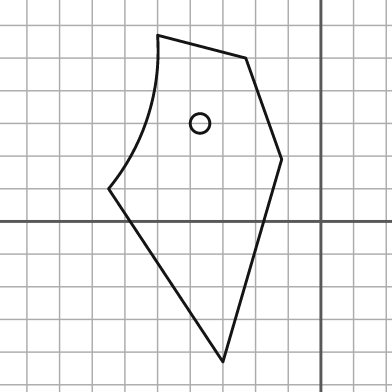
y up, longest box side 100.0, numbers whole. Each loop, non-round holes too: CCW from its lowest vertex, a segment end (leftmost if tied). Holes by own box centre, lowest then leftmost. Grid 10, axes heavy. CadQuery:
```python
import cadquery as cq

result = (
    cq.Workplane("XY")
    .moveTo(-30.0, -43.0)
    .lineTo(-12.0, 19.0)
    .lineTo(-23.0, 50.0)
    .lineTo(-50.0, 57.0)
    .threePointArc((-53.0, 32.0), (-65.0, 10.0))
    .close()
    .moveTo(-37.0, 30.0)
    .circle(3.0)
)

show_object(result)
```